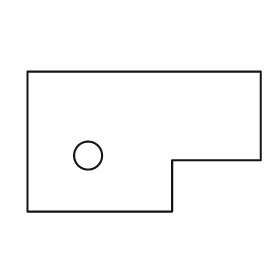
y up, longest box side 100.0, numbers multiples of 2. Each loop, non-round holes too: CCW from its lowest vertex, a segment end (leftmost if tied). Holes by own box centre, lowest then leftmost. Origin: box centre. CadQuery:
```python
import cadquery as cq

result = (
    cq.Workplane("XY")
    .moveTo(-50.0, -30.0)
    .lineTo(12.0, -30.0)
    .lineTo(12.0, -8.0)
    .lineTo(50.0, -8.0)
    .lineTo(50.0, 30.0)
    .lineTo(-50.0, 30.0)
    .close()
    .moveTo(-24.0, -6.0)
    .circle(6.0)
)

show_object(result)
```